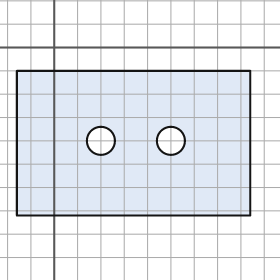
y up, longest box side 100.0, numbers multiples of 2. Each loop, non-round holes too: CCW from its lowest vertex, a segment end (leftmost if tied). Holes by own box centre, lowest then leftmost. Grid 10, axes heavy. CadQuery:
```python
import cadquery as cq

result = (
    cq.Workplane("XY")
    .moveTo(-16.0, -72.0)
    .lineTo(84.0, -72.0)
    .lineTo(84.0, -10.0)
    .lineTo(-16.0, -10.0)
    .close()
    .moveTo(20.0, -40.0)
    .circle(6.0)
    .moveTo(50.0, -40.0)
    .circle(6.0)
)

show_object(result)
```